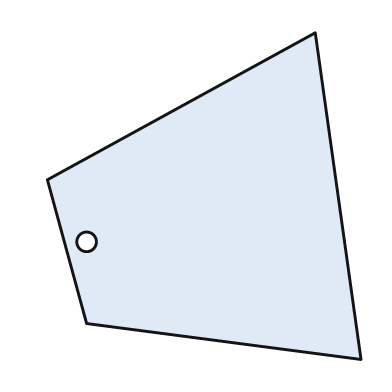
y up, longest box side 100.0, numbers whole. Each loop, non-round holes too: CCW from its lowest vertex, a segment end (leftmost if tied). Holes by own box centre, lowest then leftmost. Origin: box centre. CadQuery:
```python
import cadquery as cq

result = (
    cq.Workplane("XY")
    .moveTo(48.0, -50.0)
    .lineTo(34.0, 50.0)
    .lineTo(-48.0, 5.0)
    .lineTo(-36.0, -39.0)
    .close()
    .moveTo(-36.0, -14.0)
    .circle(3.0)
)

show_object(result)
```